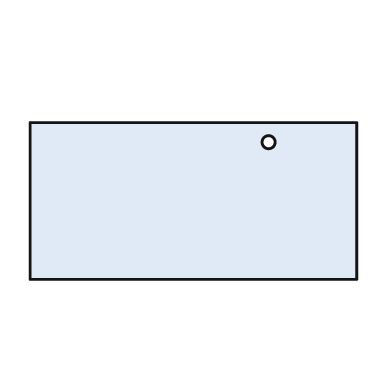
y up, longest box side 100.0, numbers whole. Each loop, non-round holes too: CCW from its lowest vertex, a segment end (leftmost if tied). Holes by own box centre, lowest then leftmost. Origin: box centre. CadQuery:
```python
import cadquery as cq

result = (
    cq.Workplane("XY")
    .moveTo(-50.0, -24.0)
    .lineTo(50.0, -24.0)
    .lineTo(50.0, 24.0)
    .lineTo(-50.0, 24.0)
    .close()
    .moveTo(23.0, 18.0)
    .circle(2.0)
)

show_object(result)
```